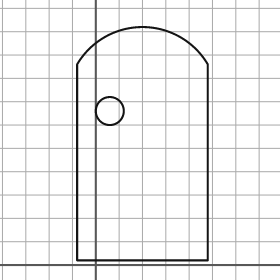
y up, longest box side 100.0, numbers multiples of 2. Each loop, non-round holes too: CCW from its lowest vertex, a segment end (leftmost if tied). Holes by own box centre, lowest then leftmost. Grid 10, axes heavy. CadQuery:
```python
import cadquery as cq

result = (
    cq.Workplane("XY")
    .moveTo(-8.0, 2.0)
    .lineTo(48.0, 2.0)
    .lineTo(48.0, 86.0)
    .threePointArc((20.0, 102.0), (-8.0, 86.0))
    .close()
    .moveTo(6.0, 66.0)
    .circle(6.0)
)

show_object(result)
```